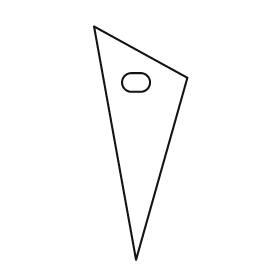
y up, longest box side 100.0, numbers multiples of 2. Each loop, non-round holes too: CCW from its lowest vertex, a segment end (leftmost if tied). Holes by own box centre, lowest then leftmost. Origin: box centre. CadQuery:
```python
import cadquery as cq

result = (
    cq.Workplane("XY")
    .moveTo(-2.0, -50.0)
    .lineTo(20.0, 28.0)
    .lineTo(-20.0, 50.0)
    .close()
    .moveTo(-4.0, 22.0)
    .lineTo(0.0, 22.0)
    .threePointArc((4.0, 26.0), (0.0, 30.0))
    .lineTo(-4.0, 30.0)
    .threePointArc((-8.0, 26.0), (-4.0, 22.0))
    .close()
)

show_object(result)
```